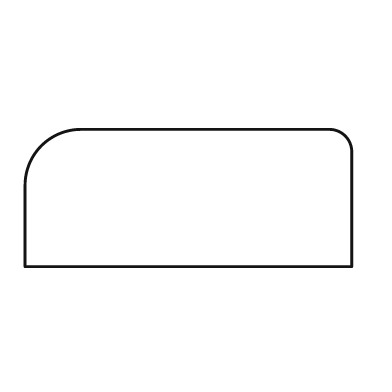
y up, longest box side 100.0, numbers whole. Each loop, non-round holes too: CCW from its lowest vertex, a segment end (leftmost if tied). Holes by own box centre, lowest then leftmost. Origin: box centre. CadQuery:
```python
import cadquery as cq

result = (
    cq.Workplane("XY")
    .moveTo(-50.0, -21.0)
    .lineTo(50.0, -21.0)
    .lineTo(50.0, 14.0)
    .threePointArc((48.0, 19.0), (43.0, 21.0))
    .lineTo(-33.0, 21.0)
    .threePointArc((-45.0, 16.0), (-50.0, 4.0))
    .close()
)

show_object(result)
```